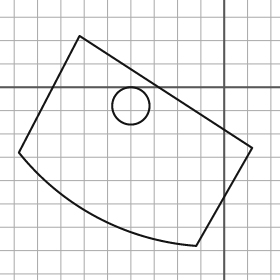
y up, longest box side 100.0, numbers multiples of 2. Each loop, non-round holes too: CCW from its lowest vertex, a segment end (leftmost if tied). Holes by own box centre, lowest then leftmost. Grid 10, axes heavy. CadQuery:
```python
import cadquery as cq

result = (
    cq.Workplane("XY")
    .moveTo(-12.0, -68.0)
    .lineTo(12.0, -26.0)
    .lineTo(-62.0, 22.0)
    .lineTo(-88.0, -28.0)
    .threePointArc((-54.0, -56.0), (-12.0, -68.0))
    .close()
    .moveTo(-40.0, -8.0)
    .circle(8.0)
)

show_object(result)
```